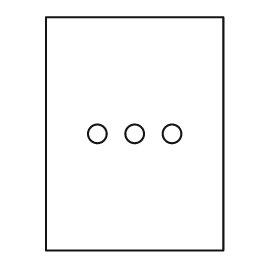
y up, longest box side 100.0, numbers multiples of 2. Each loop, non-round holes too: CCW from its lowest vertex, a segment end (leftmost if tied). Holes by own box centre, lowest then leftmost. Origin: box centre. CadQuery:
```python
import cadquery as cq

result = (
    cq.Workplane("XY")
    .moveTo(-38.0, -50.0)
    .lineTo(38.0, -50.0)
    .lineTo(38.0, 50.0)
    .lineTo(-38.0, 50.0)
    .close()
    .moveTo(-16.0, 0.0)
    .circle(4.0)
    .moveTo(0.0, 0.0)
    .circle(4.0)
    .moveTo(16.0, 0.0)
    .circle(4.0)
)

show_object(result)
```